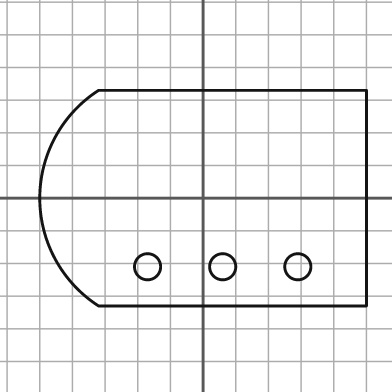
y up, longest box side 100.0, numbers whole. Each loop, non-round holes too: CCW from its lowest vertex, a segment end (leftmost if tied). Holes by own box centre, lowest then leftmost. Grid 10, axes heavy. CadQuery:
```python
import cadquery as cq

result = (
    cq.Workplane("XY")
    .moveTo(-32.0, -33.0)
    .lineTo(50.0, -33.0)
    .lineTo(50.0, 33.0)
    .lineTo(-32.0, 33.0)
    .threePointArc((-50.0, 0.0), (-32.0, -33.0))
    .close()
    .moveTo(-17.0, -21.0)
    .circle(4.0)
    .moveTo(6.0, -21.0)
    .circle(4.0)
    .moveTo(29.0, -21.0)
    .circle(4.0)
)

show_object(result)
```